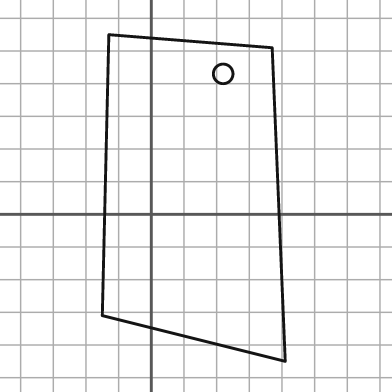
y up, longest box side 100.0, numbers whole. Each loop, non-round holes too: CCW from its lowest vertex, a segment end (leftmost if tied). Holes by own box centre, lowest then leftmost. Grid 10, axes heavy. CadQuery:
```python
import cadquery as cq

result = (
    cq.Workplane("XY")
    .moveTo(41.0, -45.0)
    .lineTo(37.0, 51.0)
    .lineTo(-13.0, 55.0)
    .lineTo(-15.0, -31.0)
    .close()
    .moveTo(22.0, 43.0)
    .circle(3.0)
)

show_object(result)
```